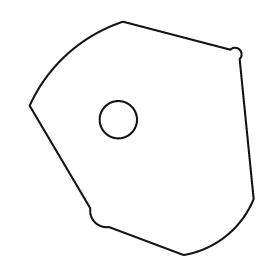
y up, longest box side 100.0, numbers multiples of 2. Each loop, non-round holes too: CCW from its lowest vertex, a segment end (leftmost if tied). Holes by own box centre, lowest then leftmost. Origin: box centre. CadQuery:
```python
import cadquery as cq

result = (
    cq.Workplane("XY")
    .moveTo(18.0, -50.0)
    .threePointArc((36.0, -42.0), (48.0, -26.0))
    .lineTo(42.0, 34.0)
    .threePointArc((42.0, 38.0), (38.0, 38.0))
    .lineTo(-8.0, 50.0)
    .threePointArc((-32.0, 36.0), (-48.0, 14.0))
    .lineTo(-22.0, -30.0)
    .threePointArc((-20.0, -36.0), (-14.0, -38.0))
    .close()
    .moveTo(-10.0, 8.0)
    .circle(8.0)
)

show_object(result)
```